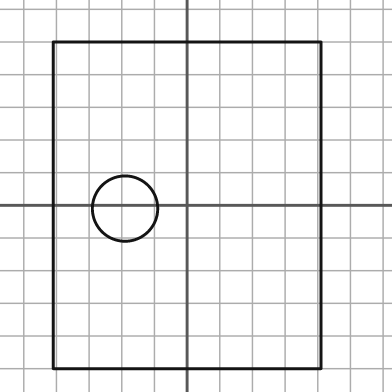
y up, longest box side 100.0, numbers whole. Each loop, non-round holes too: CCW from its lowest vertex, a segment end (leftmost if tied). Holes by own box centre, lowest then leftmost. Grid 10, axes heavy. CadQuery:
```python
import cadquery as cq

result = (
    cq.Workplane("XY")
    .moveTo(-41.0, -50.0)
    .lineTo(41.0, -50.0)
    .lineTo(41.0, 50.0)
    .lineTo(-41.0, 50.0)
    .close()
    .moveTo(-19.0, -1.0)
    .circle(10.0)
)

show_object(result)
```